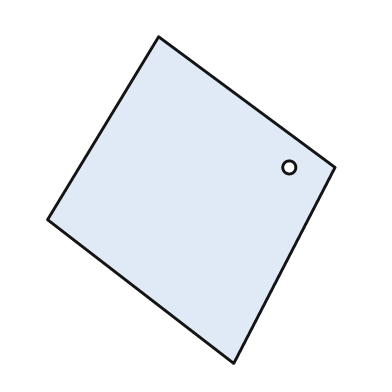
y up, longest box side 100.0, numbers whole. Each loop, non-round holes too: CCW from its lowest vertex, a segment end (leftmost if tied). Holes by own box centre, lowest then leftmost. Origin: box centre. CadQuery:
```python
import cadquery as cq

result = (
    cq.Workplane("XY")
    .moveTo(13.0, -50.0)
    .lineTo(44.0, 10.0)
    .lineTo(-10.0, 50.0)
    .lineTo(-44.0, -6.0)
    .close()
    .moveTo(30.0, 10.0)
    .circle(2.0)
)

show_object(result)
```